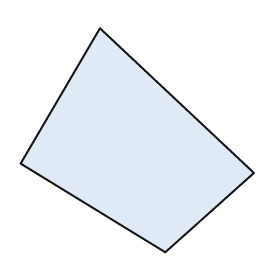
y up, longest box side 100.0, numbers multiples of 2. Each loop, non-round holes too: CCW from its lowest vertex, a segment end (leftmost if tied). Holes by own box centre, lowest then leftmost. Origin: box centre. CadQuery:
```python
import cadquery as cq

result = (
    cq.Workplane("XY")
    .moveTo(12.0, -48.0)
    .lineTo(50.0, -14.0)
    .lineTo(-16.0, 48.0)
    .lineTo(-50.0, -10.0)
    .close()
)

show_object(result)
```